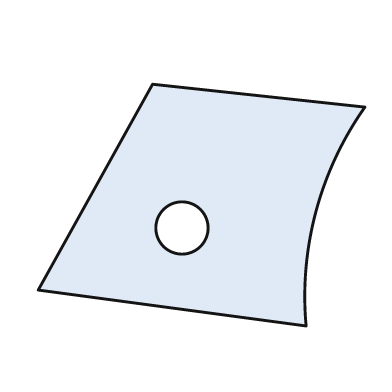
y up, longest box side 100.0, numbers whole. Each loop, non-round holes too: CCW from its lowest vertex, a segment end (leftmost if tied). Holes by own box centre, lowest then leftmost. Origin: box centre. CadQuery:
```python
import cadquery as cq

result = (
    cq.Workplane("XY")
    .moveTo(32.0, -37.0)
    .threePointArc((35.0, -2.0), (50.0, 30.0))
    .lineTo(-15.0, 37.0)
    .lineTo(-50.0, -26.0)
    .close()
    .moveTo(-6.0, -7.0)
    .circle(8.0)
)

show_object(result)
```